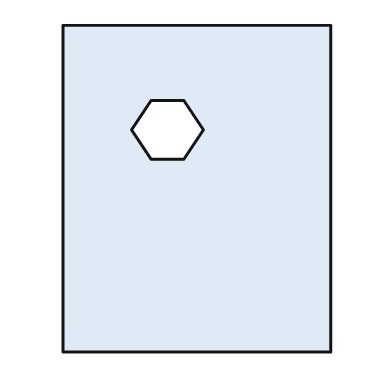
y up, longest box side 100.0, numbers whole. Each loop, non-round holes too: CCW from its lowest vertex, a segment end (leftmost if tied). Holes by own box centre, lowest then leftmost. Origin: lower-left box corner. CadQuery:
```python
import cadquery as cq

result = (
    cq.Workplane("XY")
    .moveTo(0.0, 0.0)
    .lineTo(82.0, 0.0)
    .lineTo(82.0, 100.0)
    .lineTo(0.0, 100.0)
    .close()
    .moveTo(27.0, 59.0)
    .lineTo(37.0, 59.0)
    .lineTo(43.0, 68.0)
    .lineTo(37.0, 77.0)
    .lineTo(27.0, 77.0)
    .lineTo(21.0, 68.0)
    .close()
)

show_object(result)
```